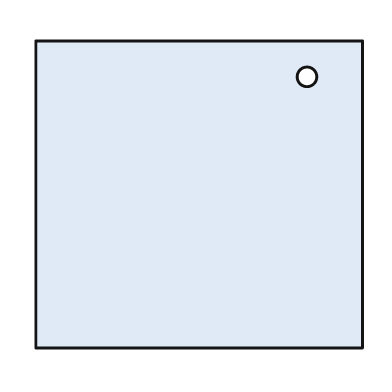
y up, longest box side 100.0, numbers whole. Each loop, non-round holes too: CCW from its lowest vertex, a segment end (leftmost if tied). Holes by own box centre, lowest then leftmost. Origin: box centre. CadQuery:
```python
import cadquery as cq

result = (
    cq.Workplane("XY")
    .moveTo(-50.0, -47.0)
    .lineTo(50.0, -47.0)
    .lineTo(50.0, 47.0)
    .lineTo(-50.0, 47.0)
    .close()
    .moveTo(33.0, 36.0)
    .circle(3.0)
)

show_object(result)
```